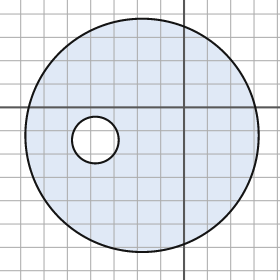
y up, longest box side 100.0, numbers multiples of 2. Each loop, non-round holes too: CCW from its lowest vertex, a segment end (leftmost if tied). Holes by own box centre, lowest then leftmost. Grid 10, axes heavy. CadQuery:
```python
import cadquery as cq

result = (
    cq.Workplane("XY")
    .moveTo(-18.0, -12.0)
    .circle(50.0)
    .moveTo(-38.0, -14.0)
    .circle(10.0)
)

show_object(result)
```